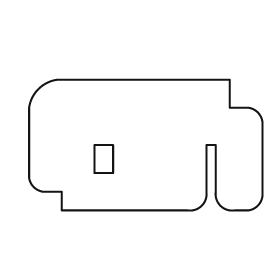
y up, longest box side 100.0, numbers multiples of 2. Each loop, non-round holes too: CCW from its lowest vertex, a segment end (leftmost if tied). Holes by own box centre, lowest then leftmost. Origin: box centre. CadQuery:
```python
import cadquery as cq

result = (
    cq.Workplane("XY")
    .moveTo(-36.0, -28.0)
    .lineTo(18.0, -28.0)
    .threePointArc((24.0, -26.0), (26.0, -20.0))
    .lineTo(26.0, 0.0)
    .lineTo(30.0, 0.0)
    .lineTo(30.0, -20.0)
    .threePointArc((32.0, -26.0), (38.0, -28.0))
    .lineTo(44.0, -28.0)
    .threePointArc((48.0, -26.0), (50.0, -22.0))
    .lineTo(50.0, 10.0)
    .threePointArc((48.0, 14.0), (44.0, 16.0))
    .lineTo(36.0, 16.0)
    .lineTo(36.0, 28.0)
    .lineTo(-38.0, 28.0)
    .threePointArc((-46.0, 24.0), (-50.0, 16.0))
    .lineTo(-50.0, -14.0)
    .threePointArc((-48.0, -18.0), (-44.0, -20.0))
    .lineTo(-36.0, -20.0)
    .close()
    .moveTo(-22.0, -12.0)
    .lineTo(-14.0, -12.0)
    .lineTo(-14.0, 0.0)
    .lineTo(-22.0, 0.0)
    .close()
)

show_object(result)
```